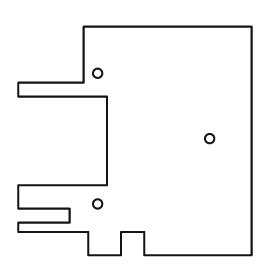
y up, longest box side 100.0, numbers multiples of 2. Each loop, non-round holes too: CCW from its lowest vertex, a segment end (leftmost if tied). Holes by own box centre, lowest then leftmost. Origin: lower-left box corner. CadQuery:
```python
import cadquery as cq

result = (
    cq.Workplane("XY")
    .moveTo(30.0, 0.0)
    .lineTo(44.0, 0.0)
    .lineTo(44.0, 10.0)
    .lineTo(54.0, 10.0)
    .lineTo(54.0, 0.0)
    .lineTo(100.0, 0.0)
    .lineTo(100.0, 98.0)
    .lineTo(28.0, 98.0)
    .lineTo(28.0, 74.0)
    .lineTo(0.0, 74.0)
    .lineTo(0.0, 68.0)
    .lineTo(38.0, 68.0)
    .lineTo(38.0, 30.0)
    .lineTo(0.0, 30.0)
    .lineTo(0.0, 20.0)
    .lineTo(22.0, 20.0)
    .lineTo(22.0, 14.0)
    .lineTo(0.0, 14.0)
    .lineTo(0.0, 10.0)
    .lineTo(30.0, 10.0)
    .close()
    .moveTo(34.0, 22.0)
    .circle(2.0)
    .moveTo(82.0, 50.0)
    .circle(2.0)
    .moveTo(34.0, 78.0)
    .circle(2.0)
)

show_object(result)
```